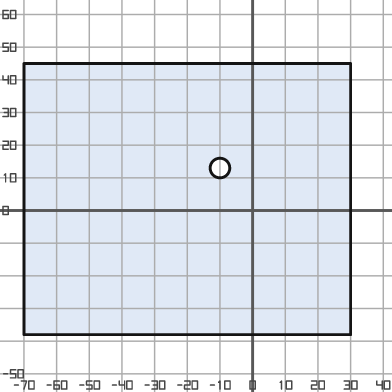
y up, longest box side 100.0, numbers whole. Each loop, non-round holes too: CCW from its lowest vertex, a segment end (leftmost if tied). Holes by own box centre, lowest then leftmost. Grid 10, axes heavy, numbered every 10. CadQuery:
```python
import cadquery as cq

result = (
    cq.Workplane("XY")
    .moveTo(-70.0, -38.0)
    .lineTo(30.0, -38.0)
    .lineTo(30.0, 45.0)
    .lineTo(-70.0, 45.0)
    .close()
    .moveTo(-10.0, 13.0)
    .circle(3.0)
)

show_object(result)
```